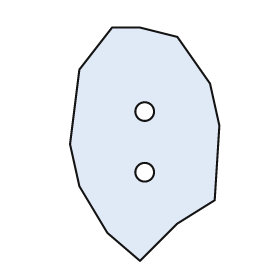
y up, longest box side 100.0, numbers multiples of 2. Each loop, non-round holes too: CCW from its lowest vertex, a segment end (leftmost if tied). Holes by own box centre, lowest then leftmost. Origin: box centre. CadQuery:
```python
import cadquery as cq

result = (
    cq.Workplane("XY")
    .moveTo(-2.0, -50.0)
    .lineTo(14.0, -34.0)
    .lineTo(30.0, -24.0)
    .lineTo(32.0, 8.0)
    .lineTo(28.0, 26.0)
    .lineTo(14.0, 46.0)
    .lineTo(-2.0, 50.0)
    .lineTo(-14.0, 50.0)
    .lineTo(-28.0, 32.0)
    .lineTo(-32.0, 0.0)
    .lineTo(-28.0, -18.0)
    .lineTo(-16.0, -38.0)
    .close()
    .moveTo(0.0, -12.0)
    .circle(4.0)
    .moveTo(0.0, 14.0)
    .circle(4.0)
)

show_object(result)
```